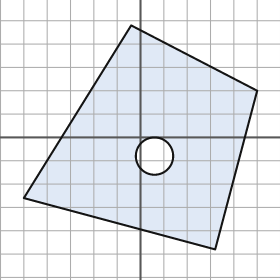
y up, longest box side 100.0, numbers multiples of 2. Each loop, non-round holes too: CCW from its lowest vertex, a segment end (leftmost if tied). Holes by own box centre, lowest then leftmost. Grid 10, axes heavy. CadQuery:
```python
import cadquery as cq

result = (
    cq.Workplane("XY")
    .moveTo(32.0, -48.0)
    .lineTo(50.0, 20.0)
    .lineTo(-4.0, 48.0)
    .lineTo(-50.0, -26.0)
    .close()
    .moveTo(6.0, -8.0)
    .circle(8.0)
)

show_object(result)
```